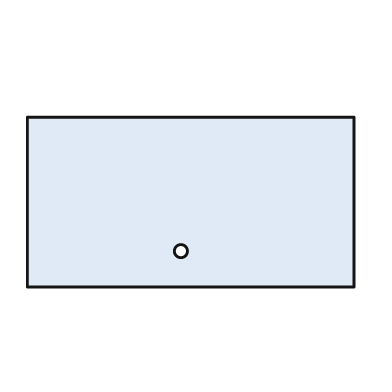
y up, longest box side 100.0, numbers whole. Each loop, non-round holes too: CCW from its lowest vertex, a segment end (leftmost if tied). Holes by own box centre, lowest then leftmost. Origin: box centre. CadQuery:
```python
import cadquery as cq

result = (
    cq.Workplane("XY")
    .moveTo(-50.0, -26.0)
    .lineTo(50.0, -26.0)
    .lineTo(50.0, 26.0)
    .lineTo(-50.0, 26.0)
    .close()
    .moveTo(-3.0, -15.0)
    .circle(2.0)
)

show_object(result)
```